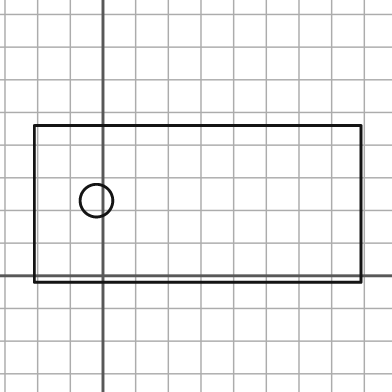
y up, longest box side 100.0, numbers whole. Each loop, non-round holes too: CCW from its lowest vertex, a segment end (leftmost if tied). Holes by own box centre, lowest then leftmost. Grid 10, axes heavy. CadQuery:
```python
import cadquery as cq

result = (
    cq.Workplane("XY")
    .moveTo(-21.0, -2.0)
    .lineTo(79.0, -2.0)
    .lineTo(79.0, 46.0)
    .lineTo(-21.0, 46.0)
    .close()
    .moveTo(-2.0, 23.0)
    .circle(5.0)
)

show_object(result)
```